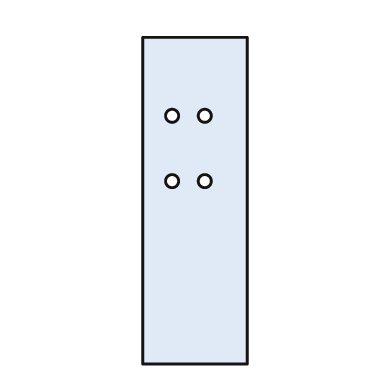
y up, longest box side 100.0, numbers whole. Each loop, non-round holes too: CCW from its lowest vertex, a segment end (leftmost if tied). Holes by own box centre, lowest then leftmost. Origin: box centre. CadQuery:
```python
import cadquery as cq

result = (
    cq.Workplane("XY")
    .moveTo(-16.0, -50.0)
    .lineTo(16.0, -50.0)
    .lineTo(16.0, 50.0)
    .lineTo(-16.0, 50.0)
    .close()
    .moveTo(-7.0, 6.0)
    .circle(2.0)
    .moveTo(3.0, 6.0)
    .circle(2.0)
    .moveTo(-7.0, 26.0)
    .circle(2.0)
    .moveTo(3.0, 26.0)
    .circle(2.0)
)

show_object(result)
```